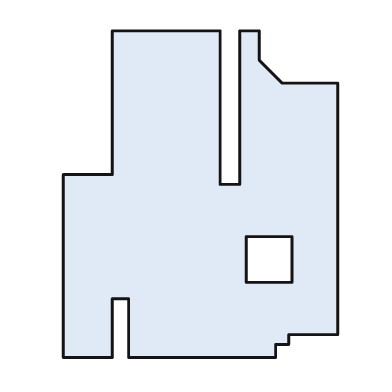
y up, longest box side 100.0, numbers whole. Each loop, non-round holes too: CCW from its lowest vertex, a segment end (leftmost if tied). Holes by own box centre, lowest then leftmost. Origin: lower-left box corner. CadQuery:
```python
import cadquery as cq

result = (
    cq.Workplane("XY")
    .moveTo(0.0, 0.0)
    .lineTo(15.0, 0.0)
    .lineTo(15.0, 18.0)
    .lineTo(20.0, 18.0)
    .lineTo(20.0, 0.0)
    .lineTo(65.0, 0.0)
    .lineTo(65.0, 4.0)
    .lineTo(69.0, 4.0)
    .lineTo(69.0, 7.0)
    .lineTo(84.0, 7.0)
    .lineTo(84.0, 84.0)
    .lineTo(67.0, 84.0)
    .lineTo(60.0, 91.0)
    .lineTo(60.0, 100.0)
    .lineTo(54.0, 100.0)
    .lineTo(54.0, 53.0)
    .lineTo(48.0, 53.0)
    .lineTo(48.0, 100.0)
    .lineTo(15.0, 100.0)
    .lineTo(15.0, 56.0)
    .lineTo(0.0, 56.0)
    .close()
    .moveTo(56.0, 23.0)
    .lineTo(70.0, 23.0)
    .lineTo(70.0, 37.0)
    .lineTo(56.0, 37.0)
    .close()
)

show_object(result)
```